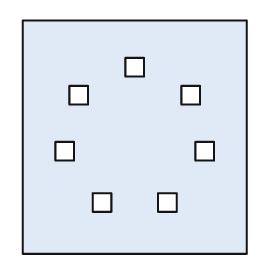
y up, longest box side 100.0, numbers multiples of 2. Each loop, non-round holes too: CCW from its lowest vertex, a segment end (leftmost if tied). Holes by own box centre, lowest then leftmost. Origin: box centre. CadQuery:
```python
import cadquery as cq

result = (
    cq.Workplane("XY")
    .moveTo(-48.0, -50.0)
    .lineTo(48.0, -50.0)
    .lineTo(48.0, 50.0)
    .lineTo(-48.0, 50.0)
    .close()
    .moveTo(-18.0, -32.0)
    .lineTo(-10.0, -32.0)
    .lineTo(-10.0, -24.0)
    .lineTo(-18.0, -24.0)
    .close()
    .moveTo(10.0, -32.0)
    .lineTo(18.0, -32.0)
    .lineTo(18.0, -24.0)
    .lineTo(10.0, -24.0)
    .close()
    .moveTo(-34.0, -10.0)
    .lineTo(-26.0, -10.0)
    .lineTo(-26.0, -2.0)
    .lineTo(-34.0, -2.0)
    .close()
    .moveTo(26.0, -10.0)
    .lineTo(34.0, -10.0)
    .lineTo(34.0, -2.0)
    .lineTo(26.0, -2.0)
    .close()
    .moveTo(-28.0, 14.0)
    .lineTo(-20.0, 14.0)
    .lineTo(-20.0, 22.0)
    .lineTo(-28.0, 22.0)
    .close()
    .moveTo(20.0, 14.0)
    .lineTo(28.0, 14.0)
    .lineTo(28.0, 22.0)
    .lineTo(20.0, 22.0)
    .close()
    .moveTo(-4.0, 26.0)
    .lineTo(4.0, 26.0)
    .lineTo(4.0, 34.0)
    .lineTo(-4.0, 34.0)
    .close()
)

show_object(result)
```